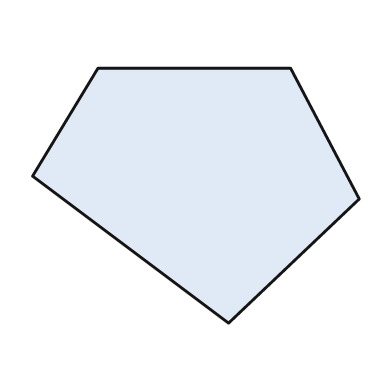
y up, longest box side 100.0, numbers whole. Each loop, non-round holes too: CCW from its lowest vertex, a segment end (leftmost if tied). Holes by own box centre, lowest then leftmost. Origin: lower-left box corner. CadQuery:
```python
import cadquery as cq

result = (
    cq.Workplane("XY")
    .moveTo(60.0, 0.0)
    .lineTo(100.0, 38.0)
    .lineTo(79.0, 78.0)
    .lineTo(20.0, 78.0)
    .lineTo(0.0, 45.0)
    .close()
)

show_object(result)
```